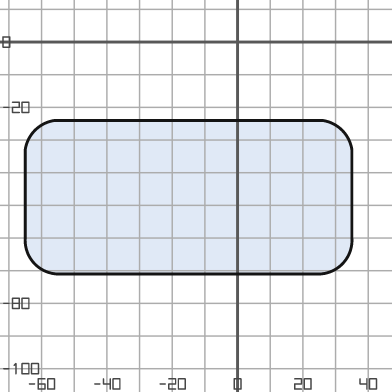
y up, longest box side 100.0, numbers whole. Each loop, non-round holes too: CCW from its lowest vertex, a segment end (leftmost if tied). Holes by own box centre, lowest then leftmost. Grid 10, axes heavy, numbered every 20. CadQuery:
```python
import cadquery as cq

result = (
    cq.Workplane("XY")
    .moveTo(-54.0, -71.0)
    .lineTo(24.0, -71.0)
    .threePointArc((32.0, -68.0), (35.0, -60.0))
    .lineTo(35.0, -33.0)
    .threePointArc((32.0, -27.0), (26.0, -24.0))
    .lineTo(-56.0, -24.0)
    .threePointArc((-62.0, -27.0), (-65.0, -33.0))
    .lineTo(-65.0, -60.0)
    .threePointArc((-62.0, -68.0), (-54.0, -71.0))
    .close()
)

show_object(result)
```